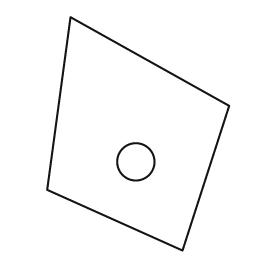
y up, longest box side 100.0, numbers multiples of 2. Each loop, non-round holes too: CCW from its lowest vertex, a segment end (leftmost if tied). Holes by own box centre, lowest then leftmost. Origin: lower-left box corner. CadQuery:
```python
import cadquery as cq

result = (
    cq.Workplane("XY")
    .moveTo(58.0, 0.0)
    .lineTo(78.0, 62.0)
    .lineTo(10.0, 100.0)
    .lineTo(0.0, 26.0)
    .close()
    .moveTo(38.0, 38.0)
    .circle(8.0)
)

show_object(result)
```